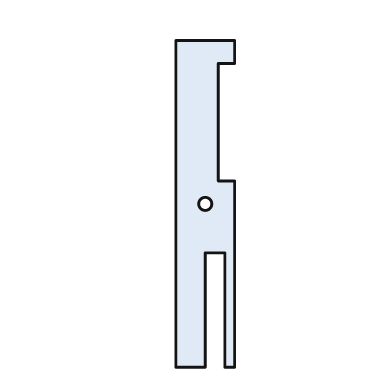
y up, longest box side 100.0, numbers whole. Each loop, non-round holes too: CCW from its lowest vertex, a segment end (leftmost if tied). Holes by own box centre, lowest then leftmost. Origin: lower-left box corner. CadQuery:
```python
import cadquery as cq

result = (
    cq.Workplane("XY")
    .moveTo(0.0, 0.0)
    .lineTo(9.0, 0.0)
    .lineTo(9.0, 35.0)
    .lineTo(15.0, 35.0)
    .lineTo(15.0, 0.0)
    .lineTo(18.0, 0.0)
    .lineTo(18.0, 57.0)
    .lineTo(13.0, 57.0)
    .lineTo(13.0, 93.0)
    .lineTo(18.0, 93.0)
    .lineTo(18.0, 100.0)
    .lineTo(0.0, 100.0)
    .close()
    .moveTo(9.0, 50.0)
    .circle(2.0)
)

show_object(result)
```